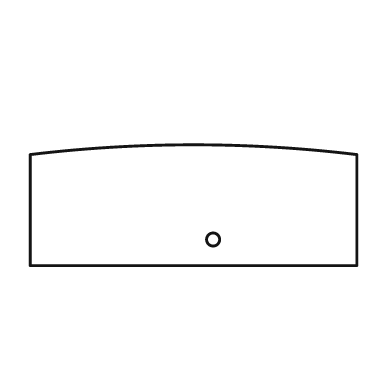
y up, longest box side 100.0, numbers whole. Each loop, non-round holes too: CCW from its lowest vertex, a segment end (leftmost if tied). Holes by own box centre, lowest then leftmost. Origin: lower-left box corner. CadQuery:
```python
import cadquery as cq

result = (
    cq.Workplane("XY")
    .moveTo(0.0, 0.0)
    .lineTo(100.0, 0.0)
    .lineTo(100.0, 34.0)
    .threePointArc((50.0, 37.0), (0.0, 34.0))
    .close()
    .moveTo(56.0, 8.0)
    .circle(2.0)
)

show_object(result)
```